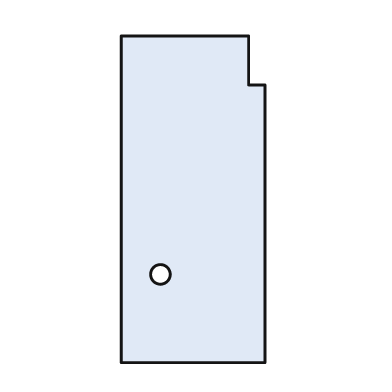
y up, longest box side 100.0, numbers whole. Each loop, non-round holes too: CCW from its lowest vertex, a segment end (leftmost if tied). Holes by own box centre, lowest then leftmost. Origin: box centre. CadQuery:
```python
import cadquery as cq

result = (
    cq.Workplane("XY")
    .moveTo(-22.0, -50.0)
    .lineTo(22.0, -50.0)
    .lineTo(22.0, 35.0)
    .lineTo(17.0, 35.0)
    .lineTo(17.0, 50.0)
    .lineTo(-22.0, 50.0)
    .close()
    .moveTo(-10.0, -23.0)
    .circle(3.0)
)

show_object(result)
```